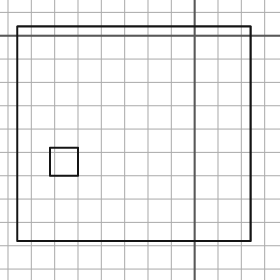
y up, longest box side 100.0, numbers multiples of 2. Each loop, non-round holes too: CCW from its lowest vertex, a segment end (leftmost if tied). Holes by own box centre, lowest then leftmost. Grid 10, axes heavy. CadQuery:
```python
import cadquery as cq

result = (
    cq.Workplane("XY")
    .moveTo(-76.0, -88.0)
    .lineTo(24.0, -88.0)
    .lineTo(24.0, 4.0)
    .lineTo(-76.0, 4.0)
    .close()
    .moveTo(-62.0, -60.0)
    .lineTo(-50.0, -60.0)
    .lineTo(-50.0, -48.0)
    .lineTo(-62.0, -48.0)
    .close()
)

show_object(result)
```